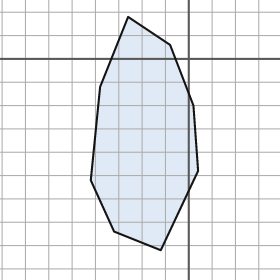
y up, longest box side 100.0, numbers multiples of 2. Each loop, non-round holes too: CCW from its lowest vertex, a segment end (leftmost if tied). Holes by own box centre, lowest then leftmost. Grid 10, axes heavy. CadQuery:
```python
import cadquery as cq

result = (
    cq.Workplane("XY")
    .moveTo(-12.0, -82.0)
    .lineTo(4.0, -48.0)
    .lineTo(2.0, -20.0)
    .lineTo(-8.0, 6.0)
    .lineTo(-26.0, 18.0)
    .lineTo(-38.0, -12.0)
    .lineTo(-42.0, -52.0)
    .lineTo(-32.0, -74.0)
    .close()
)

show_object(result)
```